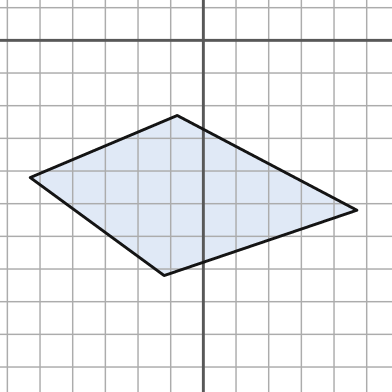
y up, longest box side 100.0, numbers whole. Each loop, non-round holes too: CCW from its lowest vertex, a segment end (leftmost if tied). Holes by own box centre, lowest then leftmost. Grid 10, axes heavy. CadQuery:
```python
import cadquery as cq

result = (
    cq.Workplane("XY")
    .moveTo(-12.0, -72.0)
    .lineTo(47.0, -52.0)
    .lineTo(-8.0, -23.0)
    .lineTo(-53.0, -42.0)
    .close()
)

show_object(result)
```